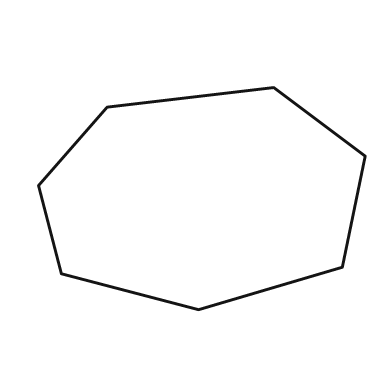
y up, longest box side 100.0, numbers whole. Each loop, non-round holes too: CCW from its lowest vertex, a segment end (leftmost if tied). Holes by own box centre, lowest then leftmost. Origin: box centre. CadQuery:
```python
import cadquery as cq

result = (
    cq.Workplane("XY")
    .moveTo(-1.0, -34.0)
    .lineTo(43.0, -21.0)
    .lineTo(50.0, 13.0)
    .lineTo(22.0, 34.0)
    .lineTo(-29.0, 28.0)
    .lineTo(-50.0, 4.0)
    .lineTo(-43.0, -23.0)
    .close()
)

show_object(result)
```